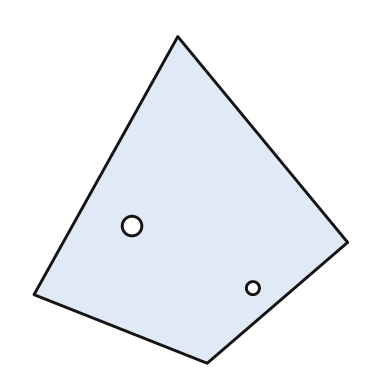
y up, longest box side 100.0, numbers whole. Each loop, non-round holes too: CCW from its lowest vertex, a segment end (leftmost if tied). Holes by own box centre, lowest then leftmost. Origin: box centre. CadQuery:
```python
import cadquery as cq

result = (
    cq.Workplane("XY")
    .moveTo(5.0, -50.0)
    .lineTo(48.0, -13.0)
    .lineTo(-4.0, 50.0)
    .lineTo(-48.0, -29.0)
    .close()
    .moveTo(19.0, -27.0)
    .circle(2.0)
    .moveTo(-18.0, -8.0)
    .circle(3.0)
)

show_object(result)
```